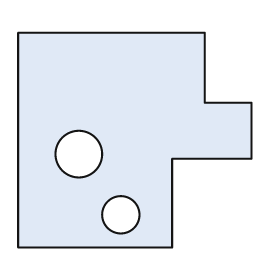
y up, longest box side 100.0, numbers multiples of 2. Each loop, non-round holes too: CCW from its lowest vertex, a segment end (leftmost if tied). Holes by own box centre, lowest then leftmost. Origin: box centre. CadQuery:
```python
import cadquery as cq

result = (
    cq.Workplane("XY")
    .moveTo(-50.0, -46.0)
    .lineTo(16.0, -46.0)
    .lineTo(16.0, -8.0)
    .lineTo(50.0, -8.0)
    .lineTo(50.0, 16.0)
    .lineTo(30.0, 16.0)
    .lineTo(30.0, 46.0)
    .lineTo(-50.0, 46.0)
    .close()
    .moveTo(-6.0, -32.0)
    .circle(8.0)
    .moveTo(-24.0, -6.0)
    .circle(10.0)
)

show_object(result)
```